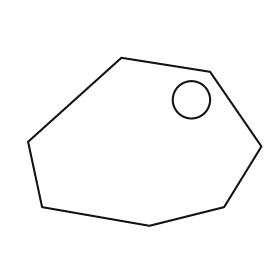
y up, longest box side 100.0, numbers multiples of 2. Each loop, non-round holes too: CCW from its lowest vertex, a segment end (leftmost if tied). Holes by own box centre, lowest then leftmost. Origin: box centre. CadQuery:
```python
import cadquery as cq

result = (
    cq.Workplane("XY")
    .moveTo(2.0, -36.0)
    .lineTo(34.0, -28.0)
    .lineTo(50.0, -2.0)
    .lineTo(28.0, 30.0)
    .lineTo(-10.0, 36.0)
    .lineTo(-50.0, 0.0)
    .lineTo(-44.0, -28.0)
    .close()
    .moveTo(20.0, 18.0)
    .circle(8.0)
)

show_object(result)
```